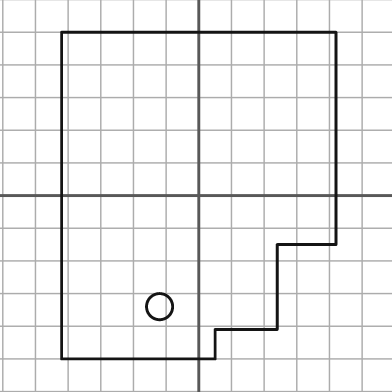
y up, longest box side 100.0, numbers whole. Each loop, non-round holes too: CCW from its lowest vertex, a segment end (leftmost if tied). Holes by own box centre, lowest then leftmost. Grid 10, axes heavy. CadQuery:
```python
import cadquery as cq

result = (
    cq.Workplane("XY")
    .moveTo(-42.0, -50.0)
    .lineTo(5.0, -50.0)
    .lineTo(5.0, -41.0)
    .lineTo(24.0, -41.0)
    .lineTo(24.0, -15.0)
    .lineTo(42.0, -15.0)
    .lineTo(42.0, 50.0)
    .lineTo(-42.0, 50.0)
    .close()
    .moveTo(-12.0, -34.0)
    .circle(4.0)
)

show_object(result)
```